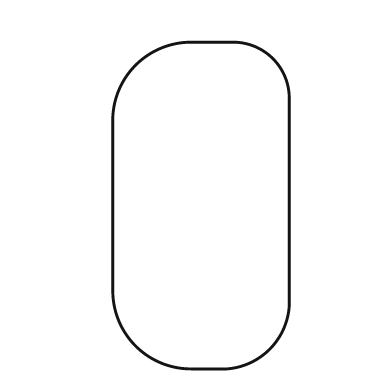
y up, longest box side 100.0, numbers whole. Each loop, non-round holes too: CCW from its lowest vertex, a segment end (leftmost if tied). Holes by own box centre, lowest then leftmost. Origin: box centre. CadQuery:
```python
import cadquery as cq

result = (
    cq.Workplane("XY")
    .moveTo(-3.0, -50.0)
    .lineTo(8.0, -50.0)
    .threePointArc((21.0, -44.0), (27.0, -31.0))
    .lineTo(27.0, 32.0)
    .threePointArc((22.0, 45.0), (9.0, 50.0))
    .lineTo(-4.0, 50.0)
    .threePointArc((-20.0, 43.0), (-27.0, 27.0))
    .lineTo(-27.0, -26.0)
    .threePointArc((-20.0, -43.0), (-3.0, -50.0))
    .close()
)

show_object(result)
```